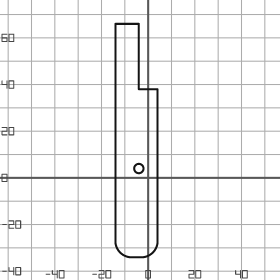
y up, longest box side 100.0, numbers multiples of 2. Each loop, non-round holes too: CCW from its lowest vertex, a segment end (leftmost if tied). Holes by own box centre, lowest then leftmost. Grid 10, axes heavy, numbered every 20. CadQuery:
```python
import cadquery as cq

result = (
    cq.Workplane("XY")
    .moveTo(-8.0, -34.0)
    .lineTo(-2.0, -34.0)
    .threePointArc((2.0, -32.0), (4.0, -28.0))
    .lineTo(4.0, 38.0)
    .lineTo(-4.0, 38.0)
    .lineTo(-4.0, 66.0)
    .lineTo(-14.0, 66.0)
    .lineTo(-14.0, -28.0)
    .threePointArc((-12.0, -32.0), (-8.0, -34.0))
    .close()
    .moveTo(-4.0, 4.0)
    .circle(2.0)
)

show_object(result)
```